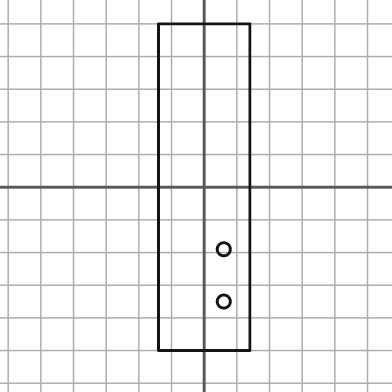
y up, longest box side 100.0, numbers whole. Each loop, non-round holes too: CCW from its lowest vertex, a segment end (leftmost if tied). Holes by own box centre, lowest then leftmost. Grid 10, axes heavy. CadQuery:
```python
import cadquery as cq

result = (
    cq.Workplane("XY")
    .moveTo(-14.0, -50.0)
    .lineTo(14.0, -50.0)
    .lineTo(14.0, 50.0)
    .lineTo(-14.0, 50.0)
    .close()
    .moveTo(6.0, -35.0)
    .circle(2.0)
    .moveTo(6.0, -19.0)
    .circle(2.0)
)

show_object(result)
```